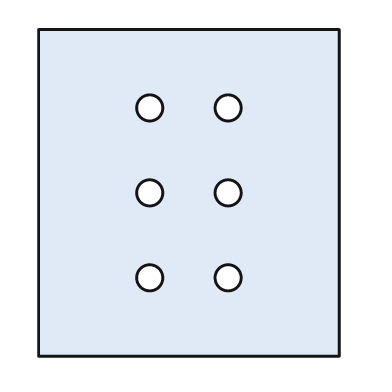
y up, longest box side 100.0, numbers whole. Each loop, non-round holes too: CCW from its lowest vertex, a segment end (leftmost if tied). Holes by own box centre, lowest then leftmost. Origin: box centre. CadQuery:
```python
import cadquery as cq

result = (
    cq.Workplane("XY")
    .moveTo(-46.0, -50.0)
    .lineTo(46.0, -50.0)
    .lineTo(46.0, 50.0)
    .lineTo(-46.0, 50.0)
    .close()
    .moveTo(-12.0, -26.0)
    .circle(4.0)
    .moveTo(12.0, -26.0)
    .circle(4.0)
    .moveTo(-12.0, 0.0)
    .circle(4.0)
    .moveTo(12.0, 0.0)
    .circle(4.0)
    .moveTo(-12.0, 26.0)
    .circle(4.0)
    .moveTo(12.0, 26.0)
    .circle(4.0)
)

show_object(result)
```